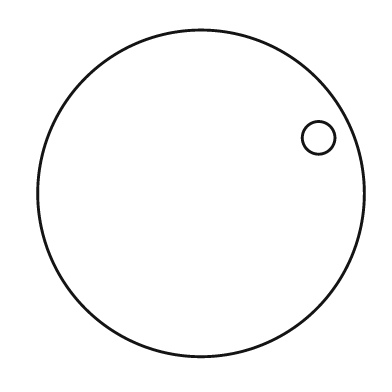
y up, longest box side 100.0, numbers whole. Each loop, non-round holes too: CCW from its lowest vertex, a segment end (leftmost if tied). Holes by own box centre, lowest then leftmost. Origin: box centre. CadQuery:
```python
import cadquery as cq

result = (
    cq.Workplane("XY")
    .moveTo(0.0, 0.0)
    .circle(50.0)
    .moveTo(36.0, 17.0)
    .circle(5.0)
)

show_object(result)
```